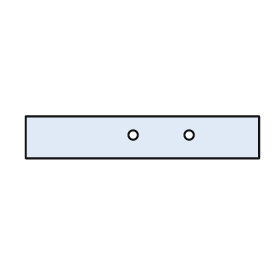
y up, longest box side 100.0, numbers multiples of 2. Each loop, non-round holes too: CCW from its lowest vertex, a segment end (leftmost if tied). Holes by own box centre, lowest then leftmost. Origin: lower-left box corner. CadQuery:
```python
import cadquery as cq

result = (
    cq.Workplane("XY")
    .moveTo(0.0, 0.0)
    .lineTo(100.0, 0.0)
    .lineTo(100.0, 18.0)
    .lineTo(0.0, 18.0)
    .close()
    .moveTo(46.0, 10.0)
    .circle(2.0)
    .moveTo(70.0, 10.0)
    .circle(2.0)
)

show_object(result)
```